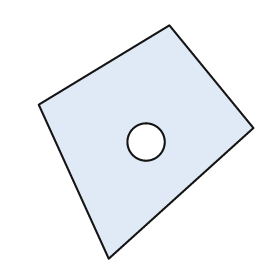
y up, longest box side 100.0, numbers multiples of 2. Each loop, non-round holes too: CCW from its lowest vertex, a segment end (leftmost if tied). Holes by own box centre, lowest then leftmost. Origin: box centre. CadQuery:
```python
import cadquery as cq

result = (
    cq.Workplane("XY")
    .moveTo(-16.0, -50.0)
    .lineTo(46.0, 6.0)
    .lineTo(10.0, 50.0)
    .lineTo(-46.0, 16.0)
    .close()
    .moveTo(0.0, 0.0)
    .circle(8.0)
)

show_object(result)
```